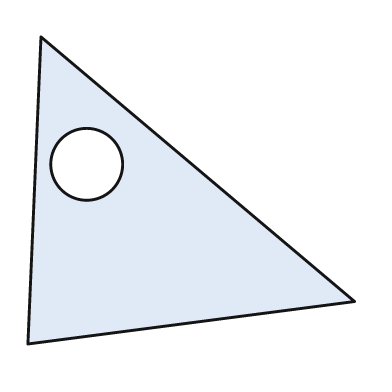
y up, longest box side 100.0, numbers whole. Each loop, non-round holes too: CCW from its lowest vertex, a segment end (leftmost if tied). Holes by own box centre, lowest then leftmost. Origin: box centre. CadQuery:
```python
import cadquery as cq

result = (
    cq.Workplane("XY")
    .moveTo(-50.0, -47.0)
    .lineTo(50.0, -34.0)
    .lineTo(-46.0, 47.0)
    .close()
    .moveTo(-32.0, 8.0)
    .circle(11.0)
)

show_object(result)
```